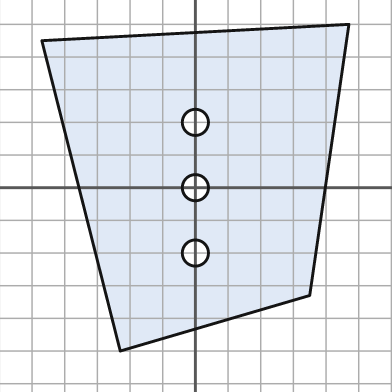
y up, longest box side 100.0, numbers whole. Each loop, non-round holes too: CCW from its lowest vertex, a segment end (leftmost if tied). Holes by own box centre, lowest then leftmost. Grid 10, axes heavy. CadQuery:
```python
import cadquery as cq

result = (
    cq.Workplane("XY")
    .moveTo(-23.0, -50.0)
    .lineTo(35.0, -33.0)
    .lineTo(47.0, 50.0)
    .lineTo(-47.0, 45.0)
    .close()
    .moveTo(0.0, -20.0)
    .circle(4.0)
    .moveTo(0.0, 0.0)
    .circle(4.0)
    .moveTo(0.0, 20.0)
    .circle(4.0)
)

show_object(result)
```